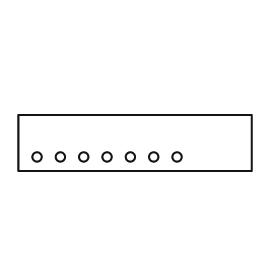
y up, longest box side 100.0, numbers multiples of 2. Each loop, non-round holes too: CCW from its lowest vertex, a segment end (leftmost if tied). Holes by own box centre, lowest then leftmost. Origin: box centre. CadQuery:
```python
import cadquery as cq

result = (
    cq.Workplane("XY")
    .moveTo(-50.0, -12.0)
    .lineTo(50.0, -12.0)
    .lineTo(50.0, 12.0)
    .lineTo(-50.0, 12.0)
    .close()
    .moveTo(-42.0, -6.0)
    .circle(2.0)
    .moveTo(-32.0, -6.0)
    .circle(2.0)
    .moveTo(-22.0, -6.0)
    .circle(2.0)
    .moveTo(-12.0, -6.0)
    .circle(2.0)
    .moveTo(-2.0, -6.0)
    .circle(2.0)
    .moveTo(8.0, -6.0)
    .circle(2.0)
    .moveTo(18.0, -6.0)
    .circle(2.0)
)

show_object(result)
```